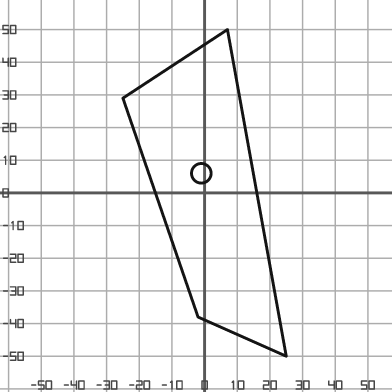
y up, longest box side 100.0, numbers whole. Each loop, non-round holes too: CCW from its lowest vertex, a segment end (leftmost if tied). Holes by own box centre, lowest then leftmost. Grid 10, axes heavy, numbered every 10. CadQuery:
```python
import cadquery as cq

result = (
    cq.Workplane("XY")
    .moveTo(25.0, -50.0)
    .lineTo(7.0, 50.0)
    .lineTo(-25.0, 29.0)
    .lineTo(-2.0, -38.0)
    .close()
    .moveTo(-1.0, 6.0)
    .circle(3.0)
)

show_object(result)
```